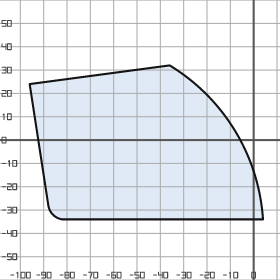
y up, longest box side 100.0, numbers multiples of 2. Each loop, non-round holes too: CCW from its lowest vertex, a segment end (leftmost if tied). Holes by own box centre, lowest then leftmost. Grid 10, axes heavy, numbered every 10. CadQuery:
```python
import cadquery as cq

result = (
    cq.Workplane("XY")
    .moveTo(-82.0, -34.0)
    .lineTo(4.0, -34.0)
    .threePointArc((-8.0, 4.0), (-36.0, 32.0))
    .lineTo(-96.0, 24.0)
    .lineTo(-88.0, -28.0)
    .threePointArc((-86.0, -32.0), (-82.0, -34.0))
    .close()
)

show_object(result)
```